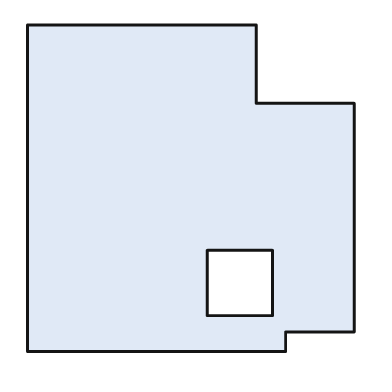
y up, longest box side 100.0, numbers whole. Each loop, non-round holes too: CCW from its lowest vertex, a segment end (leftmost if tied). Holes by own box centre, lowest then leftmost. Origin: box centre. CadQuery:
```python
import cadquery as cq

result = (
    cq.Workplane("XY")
    .moveTo(-50.0, -50.0)
    .lineTo(29.0, -50.0)
    .lineTo(29.0, -44.0)
    .lineTo(50.0, -44.0)
    .lineTo(50.0, 26.0)
    .lineTo(20.0, 26.0)
    .lineTo(20.0, 50.0)
    .lineTo(-50.0, 50.0)
    .close()
    .moveTo(5.0, -39.0)
    .lineTo(25.0, -39.0)
    .lineTo(25.0, -19.0)
    .lineTo(5.0, -19.0)
    .close()
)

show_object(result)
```